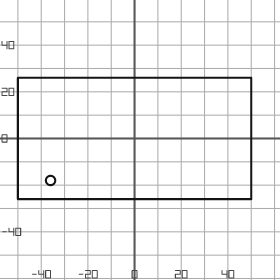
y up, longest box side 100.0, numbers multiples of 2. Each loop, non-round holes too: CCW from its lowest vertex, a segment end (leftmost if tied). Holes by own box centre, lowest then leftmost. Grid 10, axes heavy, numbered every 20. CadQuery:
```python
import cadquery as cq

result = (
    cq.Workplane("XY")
    .moveTo(-50.0, -26.0)
    .lineTo(50.0, -26.0)
    .lineTo(50.0, 26.0)
    .lineTo(-50.0, 26.0)
    .close()
    .moveTo(-36.0, -18.0)
    .circle(2.0)
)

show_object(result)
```